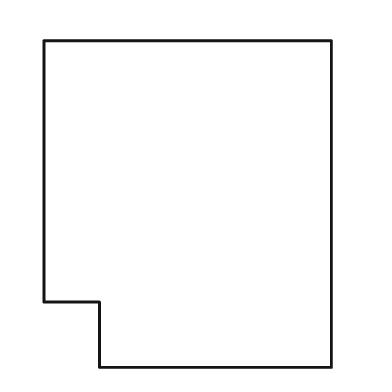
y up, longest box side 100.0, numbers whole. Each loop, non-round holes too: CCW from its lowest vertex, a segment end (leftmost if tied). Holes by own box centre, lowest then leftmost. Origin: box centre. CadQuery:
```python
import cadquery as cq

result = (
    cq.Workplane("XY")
    .moveTo(-27.0, -50.0)
    .lineTo(44.0, -50.0)
    .lineTo(44.0, 50.0)
    .lineTo(-44.0, 50.0)
    .lineTo(-44.0, -30.0)
    .lineTo(-27.0, -30.0)
    .close()
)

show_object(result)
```